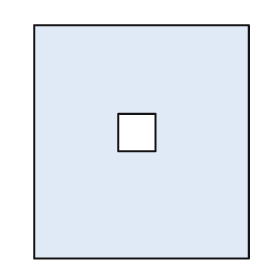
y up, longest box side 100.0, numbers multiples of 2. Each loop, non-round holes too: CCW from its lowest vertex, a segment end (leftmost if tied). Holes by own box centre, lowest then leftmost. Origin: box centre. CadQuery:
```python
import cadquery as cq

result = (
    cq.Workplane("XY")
    .moveTo(-46.0, -50.0)
    .lineTo(46.0, -50.0)
    .lineTo(46.0, 50.0)
    .lineTo(-46.0, 50.0)
    .close()
    .moveTo(-10.0, -4.0)
    .lineTo(6.0, -4.0)
    .lineTo(6.0, 12.0)
    .lineTo(-10.0, 12.0)
    .close()
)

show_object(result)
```